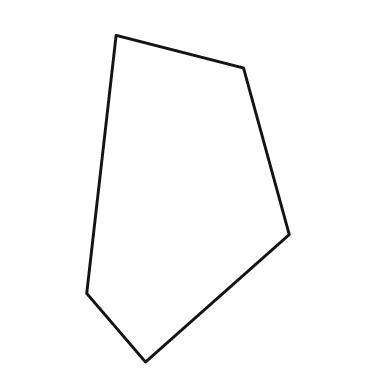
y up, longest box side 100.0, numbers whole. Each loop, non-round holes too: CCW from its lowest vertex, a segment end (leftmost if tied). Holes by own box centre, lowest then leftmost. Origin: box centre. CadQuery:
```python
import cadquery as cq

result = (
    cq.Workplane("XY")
    .moveTo(-13.0, -50.0)
    .lineTo(31.0, -11.0)
    .lineTo(17.0, 40.0)
    .lineTo(-22.0, 50.0)
    .lineTo(-31.0, -29.0)
    .close()
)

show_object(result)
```